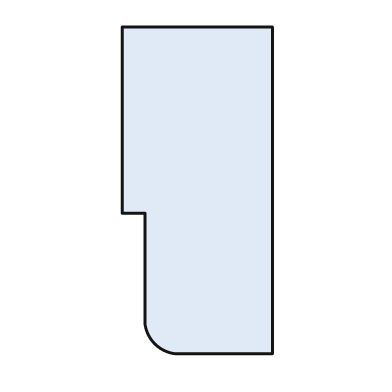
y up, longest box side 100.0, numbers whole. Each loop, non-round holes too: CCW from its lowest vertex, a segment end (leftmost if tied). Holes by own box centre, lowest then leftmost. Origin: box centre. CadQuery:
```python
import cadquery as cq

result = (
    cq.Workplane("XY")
    .moveTo(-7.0, -50.0)
    .lineTo(23.0, -50.0)
    .lineTo(23.0, 50.0)
    .lineTo(-23.0, 50.0)
    .lineTo(-23.0, -7.0)
    .lineTo(-16.0, -7.0)
    .lineTo(-16.0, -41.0)
    .threePointArc((-13.0, -47.0), (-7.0, -50.0))
    .close()
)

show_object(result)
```